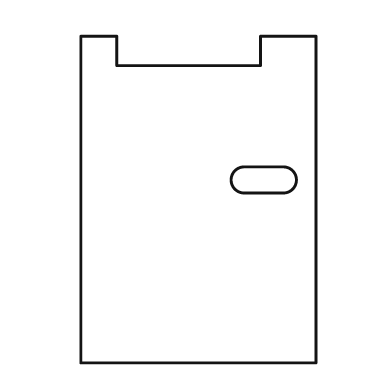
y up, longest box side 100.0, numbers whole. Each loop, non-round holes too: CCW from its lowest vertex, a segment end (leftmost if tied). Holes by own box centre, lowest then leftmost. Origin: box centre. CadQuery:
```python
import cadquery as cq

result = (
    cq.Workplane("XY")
    .moveTo(-36.0, -50.0)
    .lineTo(36.0, -50.0)
    .lineTo(36.0, 50.0)
    .lineTo(19.0, 50.0)
    .lineTo(19.0, 41.0)
    .lineTo(-25.0, 41.0)
    .lineTo(-25.0, 50.0)
    .lineTo(-36.0, 50.0)
    .close()
    .moveTo(14.0, 2.0)
    .lineTo(26.0, 2.0)
    .threePointArc((30.0, 6.0), (26.0, 10.0))
    .lineTo(14.0, 10.0)
    .threePointArc((10.0, 6.0), (14.0, 2.0))
    .close()
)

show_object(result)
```